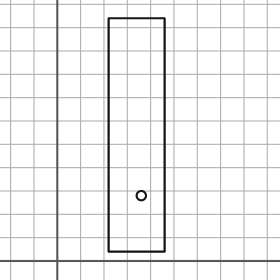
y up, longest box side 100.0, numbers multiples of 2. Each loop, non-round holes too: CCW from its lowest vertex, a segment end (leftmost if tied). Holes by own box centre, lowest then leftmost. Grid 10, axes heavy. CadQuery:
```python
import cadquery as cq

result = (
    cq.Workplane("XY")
    .moveTo(22.0, 4.0)
    .lineTo(46.0, 4.0)
    .lineTo(46.0, 104.0)
    .lineTo(22.0, 104.0)
    .close()
    .moveTo(36.0, 28.0)
    .circle(2.0)
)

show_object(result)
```